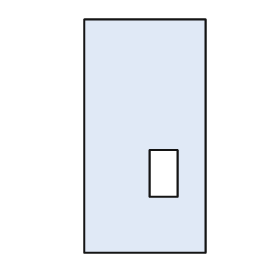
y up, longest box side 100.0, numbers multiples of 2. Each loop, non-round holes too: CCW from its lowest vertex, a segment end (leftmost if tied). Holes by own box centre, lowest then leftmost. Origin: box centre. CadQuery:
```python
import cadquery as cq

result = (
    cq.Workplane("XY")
    .moveTo(-26.0, -50.0)
    .lineTo(26.0, -50.0)
    .lineTo(26.0, 50.0)
    .lineTo(-26.0, 50.0)
    .close()
    .moveTo(2.0, -26.0)
    .lineTo(14.0, -26.0)
    .lineTo(14.0, -6.0)
    .lineTo(2.0, -6.0)
    .close()
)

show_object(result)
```